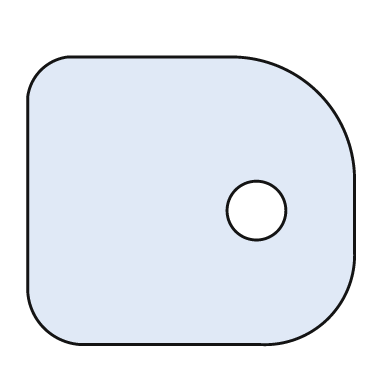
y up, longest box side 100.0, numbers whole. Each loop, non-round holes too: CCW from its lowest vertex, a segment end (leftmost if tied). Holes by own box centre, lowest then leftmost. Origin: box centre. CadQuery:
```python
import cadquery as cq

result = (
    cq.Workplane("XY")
    .moveTo(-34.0, -44.0)
    .lineTo(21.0, -44.0)
    .threePointArc((42.0, -36.0), (50.0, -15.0))
    .lineTo(50.0, 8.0)
    .threePointArc((39.0, 33.0), (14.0, 44.0))
    .lineTo(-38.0, 44.0)
    .threePointArc((-46.0, 40.0), (-50.0, 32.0))
    .lineTo(-50.0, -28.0)
    .threePointArc((-45.0, -39.0), (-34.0, -44.0))
    .close()
    .moveTo(20.0, -3.0)
    .circle(9.0)
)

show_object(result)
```